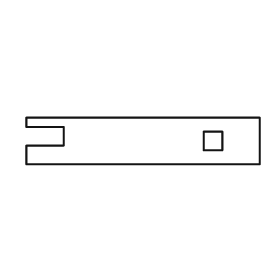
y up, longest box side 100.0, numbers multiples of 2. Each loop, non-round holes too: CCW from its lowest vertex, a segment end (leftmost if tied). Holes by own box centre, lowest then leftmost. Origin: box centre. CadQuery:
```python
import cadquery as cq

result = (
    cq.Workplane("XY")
    .moveTo(-50.0, -10.0)
    .lineTo(50.0, -10.0)
    .lineTo(50.0, 10.0)
    .lineTo(-50.0, 10.0)
    .lineTo(-50.0, 6.0)
    .lineTo(-34.0, 6.0)
    .lineTo(-34.0, -2.0)
    .lineTo(-50.0, -2.0)
    .close()
    .moveTo(26.0, -4.0)
    .lineTo(34.0, -4.0)
    .lineTo(34.0, 4.0)
    .lineTo(26.0, 4.0)
    .close()
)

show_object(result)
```